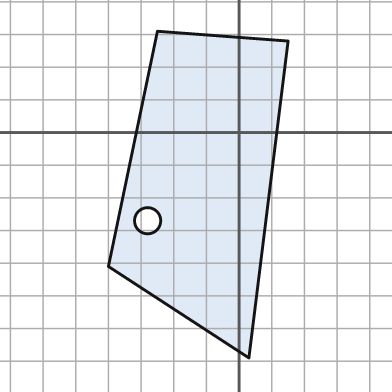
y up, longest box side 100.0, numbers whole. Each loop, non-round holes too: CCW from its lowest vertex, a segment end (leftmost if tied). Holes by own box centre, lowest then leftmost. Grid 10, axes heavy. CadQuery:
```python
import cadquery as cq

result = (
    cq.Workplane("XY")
    .moveTo(3.0, -69.0)
    .lineTo(15.0, 28.0)
    .lineTo(-25.0, 31.0)
    .lineTo(-40.0, -41.0)
    .close()
    .moveTo(-28.0, -27.0)
    .circle(4.0)
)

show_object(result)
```